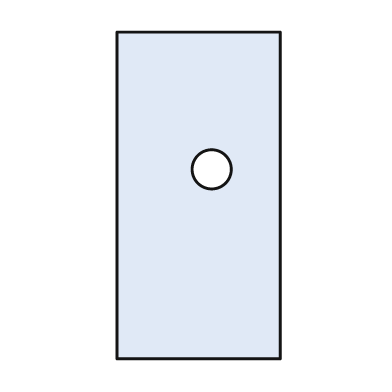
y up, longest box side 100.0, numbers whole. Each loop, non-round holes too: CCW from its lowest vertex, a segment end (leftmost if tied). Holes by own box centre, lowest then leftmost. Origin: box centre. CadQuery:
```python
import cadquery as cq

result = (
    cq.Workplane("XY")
    .moveTo(-25.0, -50.0)
    .lineTo(25.0, -50.0)
    .lineTo(25.0, 50.0)
    .lineTo(-25.0, 50.0)
    .close()
    .moveTo(4.0, 8.0)
    .circle(6.0)
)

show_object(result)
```